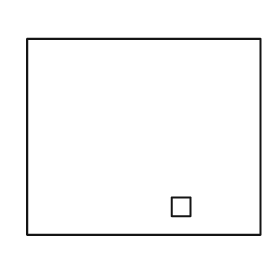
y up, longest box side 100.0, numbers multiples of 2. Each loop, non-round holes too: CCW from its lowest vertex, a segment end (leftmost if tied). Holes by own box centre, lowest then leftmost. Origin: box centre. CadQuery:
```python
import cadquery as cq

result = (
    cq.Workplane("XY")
    .moveTo(-50.0, -42.0)
    .lineTo(50.0, -42.0)
    .lineTo(50.0, 42.0)
    .lineTo(-50.0, 42.0)
    .close()
    .moveTo(12.0, -34.0)
    .lineTo(20.0, -34.0)
    .lineTo(20.0, -26.0)
    .lineTo(12.0, -26.0)
    .close()
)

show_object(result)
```